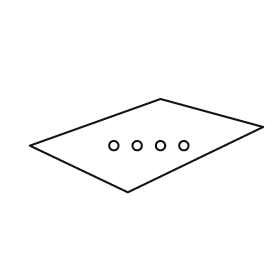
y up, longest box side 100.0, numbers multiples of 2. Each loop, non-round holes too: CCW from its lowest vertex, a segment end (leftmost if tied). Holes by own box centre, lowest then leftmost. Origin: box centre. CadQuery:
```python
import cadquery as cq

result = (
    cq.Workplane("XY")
    .moveTo(-8.0, -20.0)
    .lineTo(50.0, 8.0)
    .lineTo(6.0, 20.0)
    .lineTo(-50.0, 0.0)
    .close()
    .moveTo(-14.0, 0.0)
    .circle(2.0)
    .moveTo(-4.0, 0.0)
    .circle(2.0)
    .moveTo(6.0, 0.0)
    .circle(2.0)
    .moveTo(16.0, 0.0)
    .circle(2.0)
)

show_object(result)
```